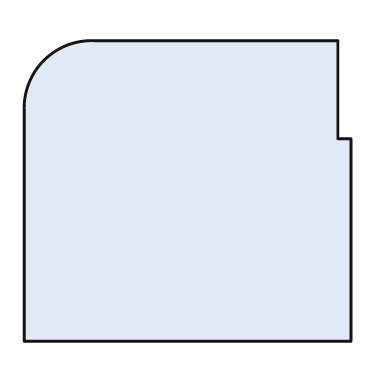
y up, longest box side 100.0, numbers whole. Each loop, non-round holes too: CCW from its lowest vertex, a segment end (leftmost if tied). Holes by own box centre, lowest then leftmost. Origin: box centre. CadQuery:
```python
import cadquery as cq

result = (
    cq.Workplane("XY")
    .moveTo(-50.0, -46.0)
    .lineTo(50.0, -46.0)
    .lineTo(50.0, 16.0)
    .lineTo(46.0, 16.0)
    .lineTo(46.0, 46.0)
    .lineTo(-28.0, 46.0)
    .threePointArc((-44.0, 40.0), (-50.0, 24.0))
    .close()
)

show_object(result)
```